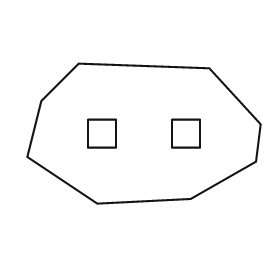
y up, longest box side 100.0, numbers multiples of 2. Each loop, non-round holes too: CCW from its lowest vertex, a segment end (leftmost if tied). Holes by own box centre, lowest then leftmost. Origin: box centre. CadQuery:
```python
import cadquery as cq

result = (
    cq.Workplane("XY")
    .moveTo(-20.0, -30.0)
    .lineTo(20.0, -28.0)
    .lineTo(48.0, -12.0)
    .lineTo(50.0, 4.0)
    .lineTo(28.0, 28.0)
    .lineTo(-28.0, 30.0)
    .lineTo(-44.0, 14.0)
    .lineTo(-50.0, -10.0)
    .close()
    .moveTo(-24.0, -6.0)
    .lineTo(-12.0, -6.0)
    .lineTo(-12.0, 6.0)
    .lineTo(-24.0, 6.0)
    .close()
    .moveTo(12.0, -6.0)
    .lineTo(24.0, -6.0)
    .lineTo(24.0, 6.0)
    .lineTo(12.0, 6.0)
    .close()
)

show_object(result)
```